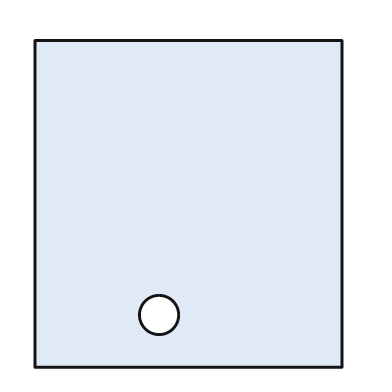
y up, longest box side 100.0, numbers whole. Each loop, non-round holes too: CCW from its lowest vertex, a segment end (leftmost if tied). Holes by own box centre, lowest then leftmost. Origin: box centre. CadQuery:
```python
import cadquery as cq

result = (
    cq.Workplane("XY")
    .moveTo(-47.0, -50.0)
    .lineTo(47.0, -50.0)
    .lineTo(47.0, 50.0)
    .lineTo(-47.0, 50.0)
    .close()
    .moveTo(-9.0, -34.0)
    .circle(6.0)
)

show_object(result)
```